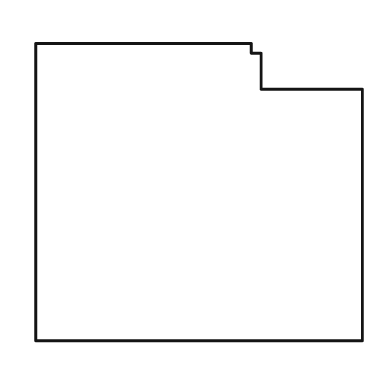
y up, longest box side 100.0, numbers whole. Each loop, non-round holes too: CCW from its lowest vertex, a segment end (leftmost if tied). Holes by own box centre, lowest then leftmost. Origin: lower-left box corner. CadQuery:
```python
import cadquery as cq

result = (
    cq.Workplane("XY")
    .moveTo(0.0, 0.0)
    .lineTo(100.0, 0.0)
    .lineTo(100.0, 77.0)
    .lineTo(69.0, 77.0)
    .lineTo(69.0, 88.0)
    .lineTo(66.0, 88.0)
    .lineTo(66.0, 91.0)
    .lineTo(0.0, 91.0)
    .close()
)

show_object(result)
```